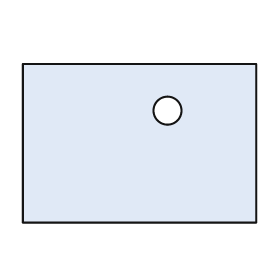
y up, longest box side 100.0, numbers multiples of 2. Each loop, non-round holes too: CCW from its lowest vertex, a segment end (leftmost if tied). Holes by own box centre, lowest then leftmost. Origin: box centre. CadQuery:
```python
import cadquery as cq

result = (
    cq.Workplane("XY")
    .moveTo(-50.0, -34.0)
    .lineTo(50.0, -34.0)
    .lineTo(50.0, 34.0)
    .lineTo(-50.0, 34.0)
    .close()
    .moveTo(12.0, 14.0)
    .circle(6.0)
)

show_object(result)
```